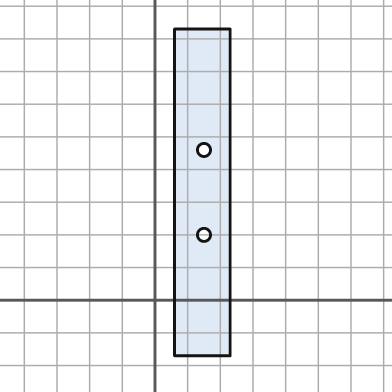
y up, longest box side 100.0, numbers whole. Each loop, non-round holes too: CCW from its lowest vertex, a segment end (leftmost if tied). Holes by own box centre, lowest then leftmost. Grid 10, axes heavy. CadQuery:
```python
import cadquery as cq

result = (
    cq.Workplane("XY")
    .moveTo(6.0, -17.0)
    .lineTo(23.0, -17.0)
    .lineTo(23.0, 83.0)
    .lineTo(6.0, 83.0)
    .close()
    .moveTo(15.0, 20.0)
    .circle(2.0)
    .moveTo(15.0, 46.0)
    .circle(2.0)
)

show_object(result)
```